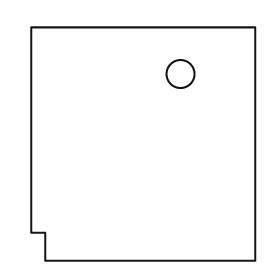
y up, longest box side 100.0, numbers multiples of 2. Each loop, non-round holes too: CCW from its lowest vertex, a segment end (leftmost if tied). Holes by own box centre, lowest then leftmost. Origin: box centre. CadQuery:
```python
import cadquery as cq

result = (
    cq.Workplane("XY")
    .moveTo(-42.0, -50.0)
    .lineTo(48.0, -50.0)
    .lineTo(48.0, 50.0)
    .lineTo(-48.0, 50.0)
    .lineTo(-48.0, -38.0)
    .lineTo(-42.0, -38.0)
    .close()
    .moveTo(16.0, 30.0)
    .circle(6.0)
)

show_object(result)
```